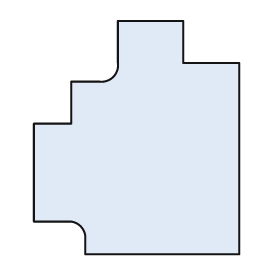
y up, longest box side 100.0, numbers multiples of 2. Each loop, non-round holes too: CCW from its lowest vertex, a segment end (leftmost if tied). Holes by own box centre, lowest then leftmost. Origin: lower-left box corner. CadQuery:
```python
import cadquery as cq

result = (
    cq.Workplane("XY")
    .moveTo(22.0, 0.0)
    .lineTo(88.0, 0.0)
    .lineTo(88.0, 82.0)
    .lineTo(64.0, 82.0)
    .lineTo(64.0, 100.0)
    .lineTo(36.0, 100.0)
    .lineTo(36.0, 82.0)
    .threePointArc((34.0, 76.0), (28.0, 74.0))
    .lineTo(16.0, 74.0)
    .lineTo(16.0, 56.0)
    .lineTo(0.0, 56.0)
    .lineTo(0.0, 14.0)
    .lineTo(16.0, 14.0)
    .threePointArc((20.0, 12.0), (22.0, 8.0))
    .close()
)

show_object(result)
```